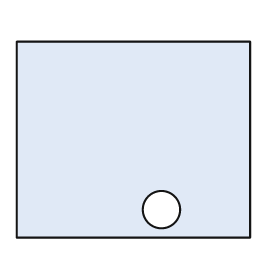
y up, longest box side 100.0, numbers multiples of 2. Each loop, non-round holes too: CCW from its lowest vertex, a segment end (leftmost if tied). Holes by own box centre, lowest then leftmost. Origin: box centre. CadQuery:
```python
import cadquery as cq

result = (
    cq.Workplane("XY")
    .moveTo(-50.0, -42.0)
    .lineTo(50.0, -42.0)
    .lineTo(50.0, 42.0)
    .lineTo(-50.0, 42.0)
    .close()
    .moveTo(12.0, -30.0)
    .circle(8.0)
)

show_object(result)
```